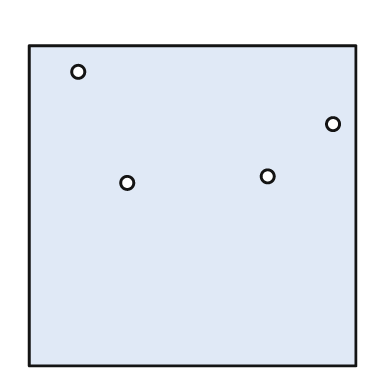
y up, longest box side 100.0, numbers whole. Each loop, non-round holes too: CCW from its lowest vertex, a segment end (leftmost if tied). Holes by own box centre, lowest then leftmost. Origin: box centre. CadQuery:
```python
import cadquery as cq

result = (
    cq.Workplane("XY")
    .moveTo(-50.0, -49.0)
    .lineTo(50.0, -49.0)
    .lineTo(50.0, 49.0)
    .lineTo(-50.0, 49.0)
    .close()
    .moveTo(-20.0, 7.0)
    .circle(2.0)
    .moveTo(23.0, 9.0)
    .circle(2.0)
    .moveTo(43.0, 25.0)
    .circle(2.0)
    .moveTo(-35.0, 41.0)
    .circle(2.0)
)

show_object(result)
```